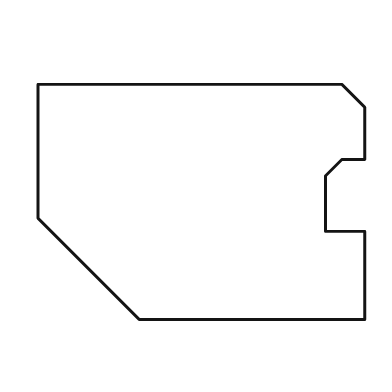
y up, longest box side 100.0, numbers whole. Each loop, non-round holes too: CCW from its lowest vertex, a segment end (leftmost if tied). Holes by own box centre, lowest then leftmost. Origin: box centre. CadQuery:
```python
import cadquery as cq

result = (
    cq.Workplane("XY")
    .moveTo(-19.0, -36.0)
    .lineTo(50.0, -36.0)
    .lineTo(50.0, -9.0)
    .lineTo(38.0, -9.0)
    .lineTo(38.0, 8.0)
    .lineTo(43.0, 13.0)
    .lineTo(50.0, 13.0)
    .lineTo(50.0, 29.0)
    .lineTo(43.0, 36.0)
    .lineTo(-50.0, 36.0)
    .lineTo(-50.0, -5.0)
    .close()
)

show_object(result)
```